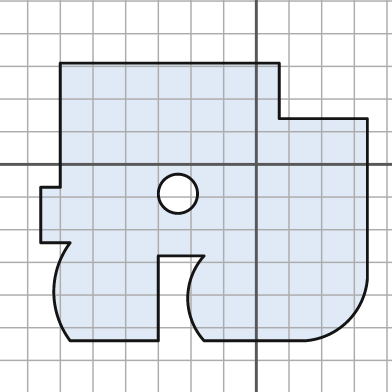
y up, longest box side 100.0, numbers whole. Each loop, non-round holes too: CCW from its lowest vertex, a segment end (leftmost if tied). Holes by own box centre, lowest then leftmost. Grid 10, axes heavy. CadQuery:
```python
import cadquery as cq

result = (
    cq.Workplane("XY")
    .moveTo(-57.0, -54.0)
    .lineTo(-30.0, -54.0)
    .lineTo(-30.0, -28.0)
    .lineTo(-16.0, -28.0)
    .threePointArc((-21.0, -41.0), (-16.0, -54.0))
    .lineTo(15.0, -54.0)
    .threePointArc((28.0, -48.0), (34.0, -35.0))
    .lineTo(34.0, 14.0)
    .lineTo(7.0, 14.0)
    .lineTo(7.0, 31.0)
    .lineTo(-60.0, 31.0)
    .lineTo(-60.0, -7.0)
    .lineTo(-66.0, -7.0)
    .lineTo(-66.0, -24.0)
    .lineTo(-57.0, -24.0)
    .threePointArc((-62.0, -39.0), (-57.0, -54.0))
    .close()
    .moveTo(-24.0, -9.0)
    .circle(6.0)
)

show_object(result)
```